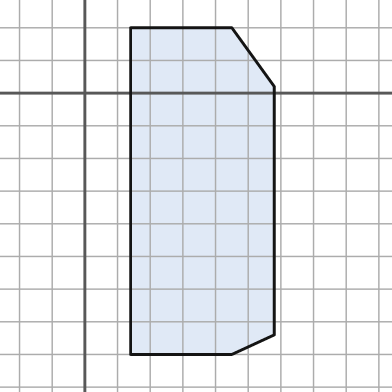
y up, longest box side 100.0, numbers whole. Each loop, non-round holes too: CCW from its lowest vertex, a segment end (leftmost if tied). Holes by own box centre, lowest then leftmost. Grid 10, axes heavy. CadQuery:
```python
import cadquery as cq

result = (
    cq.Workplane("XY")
    .moveTo(14.0, -80.0)
    .lineTo(45.0, -80.0)
    .lineTo(58.0, -74.0)
    .lineTo(58.0, 2.0)
    .lineTo(45.0, 20.0)
    .lineTo(14.0, 20.0)
    .close()
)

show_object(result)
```